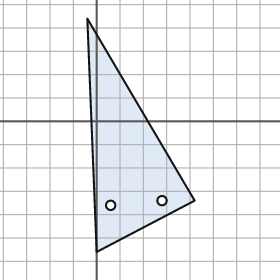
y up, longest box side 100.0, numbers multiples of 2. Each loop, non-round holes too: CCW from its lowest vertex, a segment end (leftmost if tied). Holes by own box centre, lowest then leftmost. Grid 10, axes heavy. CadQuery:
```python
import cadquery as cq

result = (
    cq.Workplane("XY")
    .moveTo(0.0, -56.0)
    .lineTo(42.0, -34.0)
    .lineTo(-4.0, 44.0)
    .close()
    .moveTo(6.0, -36.0)
    .circle(2.0)
    .moveTo(28.0, -34.0)
    .circle(2.0)
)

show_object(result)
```